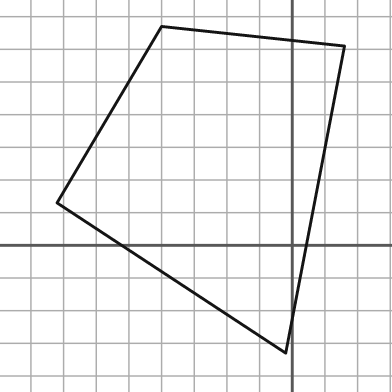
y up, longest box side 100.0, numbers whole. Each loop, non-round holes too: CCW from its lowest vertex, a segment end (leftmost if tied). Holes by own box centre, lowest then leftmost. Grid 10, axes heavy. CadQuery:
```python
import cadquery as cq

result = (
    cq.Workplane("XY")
    .moveTo(-2.0, -33.0)
    .lineTo(16.0, 61.0)
    .lineTo(-40.0, 67.0)
    .lineTo(-72.0, 13.0)
    .close()
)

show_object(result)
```